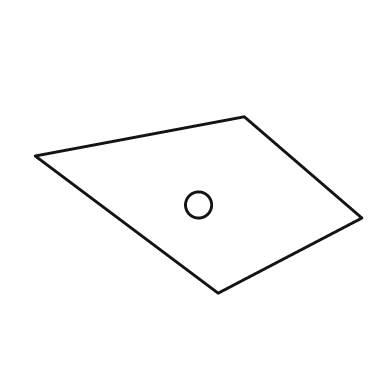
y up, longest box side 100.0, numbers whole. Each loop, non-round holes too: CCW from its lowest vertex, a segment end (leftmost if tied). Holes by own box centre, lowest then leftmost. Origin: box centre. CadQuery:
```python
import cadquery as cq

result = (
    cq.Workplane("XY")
    .moveTo(6.0, -27.0)
    .lineTo(50.0, -4.0)
    .lineTo(14.0, 27.0)
    .lineTo(-50.0, 15.0)
    .close()
    .moveTo(0.0, 0.0)
    .circle(4.0)
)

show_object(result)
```